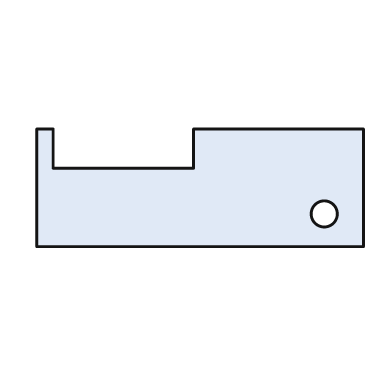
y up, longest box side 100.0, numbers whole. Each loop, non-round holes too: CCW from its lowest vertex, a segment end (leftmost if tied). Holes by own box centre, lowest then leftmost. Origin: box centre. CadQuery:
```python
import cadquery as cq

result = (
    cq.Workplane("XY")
    .moveTo(-50.0, -18.0)
    .lineTo(50.0, -18.0)
    .lineTo(50.0, 18.0)
    .lineTo(-2.0, 18.0)
    .lineTo(-2.0, 6.0)
    .lineTo(-45.0, 6.0)
    .lineTo(-45.0, 18.0)
    .lineTo(-50.0, 18.0)
    .close()
    .moveTo(38.0, -8.0)
    .circle(4.0)
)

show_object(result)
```